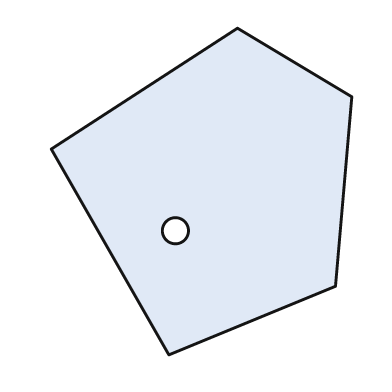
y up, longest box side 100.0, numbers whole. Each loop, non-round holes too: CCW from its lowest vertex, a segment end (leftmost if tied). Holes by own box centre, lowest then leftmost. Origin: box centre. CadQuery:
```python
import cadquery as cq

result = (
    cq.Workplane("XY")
    .moveTo(-10.0, -50.0)
    .lineTo(41.0, -29.0)
    .lineTo(46.0, 29.0)
    .lineTo(11.0, 50.0)
    .lineTo(-46.0, 13.0)
    .close()
    .moveTo(-8.0, -12.0)
    .circle(4.0)
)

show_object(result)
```